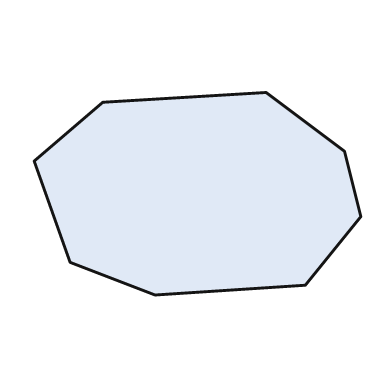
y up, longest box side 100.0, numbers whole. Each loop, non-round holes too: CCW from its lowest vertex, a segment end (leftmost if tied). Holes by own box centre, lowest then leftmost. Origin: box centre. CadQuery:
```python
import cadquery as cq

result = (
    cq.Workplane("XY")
    .moveTo(-13.0, -31.0)
    .lineTo(33.0, -28.0)
    .lineTo(50.0, -7.0)
    .lineTo(45.0, 13.0)
    .lineTo(21.0, 31.0)
    .lineTo(-29.0, 28.0)
    .lineTo(-50.0, 10.0)
    .lineTo(-39.0, -21.0)
    .close()
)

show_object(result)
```